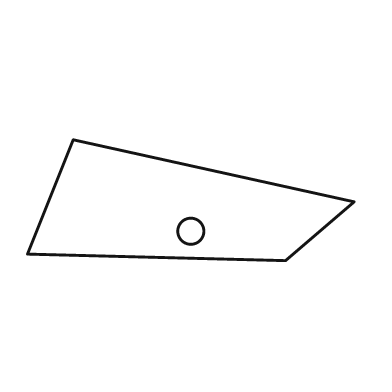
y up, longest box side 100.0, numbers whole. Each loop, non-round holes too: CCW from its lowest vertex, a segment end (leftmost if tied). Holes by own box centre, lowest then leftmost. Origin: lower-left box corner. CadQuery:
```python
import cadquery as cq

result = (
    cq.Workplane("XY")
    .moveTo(79.0, 0.0)
    .lineTo(100.0, 18.0)
    .lineTo(14.0, 37.0)
    .lineTo(0.0, 2.0)
    .close()
    .moveTo(50.0, 9.0)
    .circle(4.0)
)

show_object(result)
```